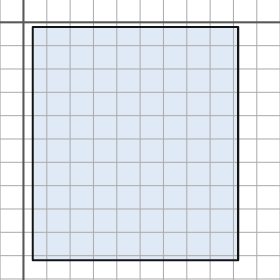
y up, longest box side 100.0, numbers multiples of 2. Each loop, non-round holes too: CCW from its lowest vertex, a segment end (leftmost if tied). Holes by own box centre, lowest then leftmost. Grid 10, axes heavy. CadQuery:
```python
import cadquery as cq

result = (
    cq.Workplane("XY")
    .moveTo(4.0, -102.0)
    .lineTo(92.0, -102.0)
    .lineTo(92.0, -2.0)
    .lineTo(4.0, -2.0)
    .close()
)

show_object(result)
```